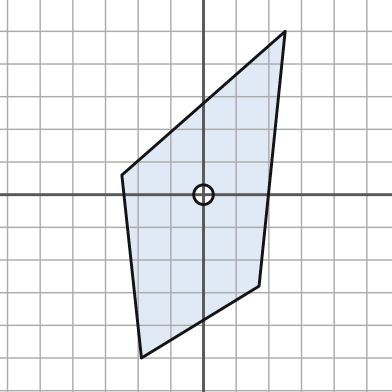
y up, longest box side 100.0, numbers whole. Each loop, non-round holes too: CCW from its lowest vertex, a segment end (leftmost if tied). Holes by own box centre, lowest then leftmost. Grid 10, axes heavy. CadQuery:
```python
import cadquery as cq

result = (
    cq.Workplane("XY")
    .moveTo(-19.0, -50.0)
    .lineTo(17.0, -28.0)
    .lineTo(25.0, 50.0)
    .lineTo(-25.0, 6.0)
    .close()
    .moveTo(0.0, 0.0)
    .circle(3.0)
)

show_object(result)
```